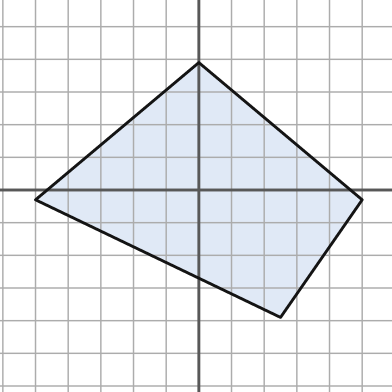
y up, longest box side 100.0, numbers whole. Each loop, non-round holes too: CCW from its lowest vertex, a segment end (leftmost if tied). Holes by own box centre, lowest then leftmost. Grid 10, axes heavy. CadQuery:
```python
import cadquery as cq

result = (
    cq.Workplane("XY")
    .moveTo(25.0, -39.0)
    .lineTo(50.0, -3.0)
    .lineTo(0.0, 39.0)
    .lineTo(-50.0, -3.0)
    .close()
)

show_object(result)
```